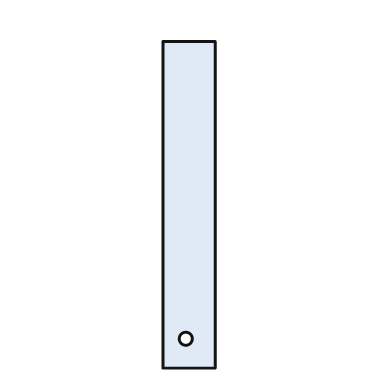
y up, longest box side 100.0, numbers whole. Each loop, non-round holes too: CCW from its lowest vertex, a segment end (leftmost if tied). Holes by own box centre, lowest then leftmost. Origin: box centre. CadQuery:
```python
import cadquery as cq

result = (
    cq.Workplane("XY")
    .moveTo(-8.0, -50.0)
    .lineTo(8.0, -50.0)
    .lineTo(8.0, 50.0)
    .lineTo(-8.0, 50.0)
    .close()
    .moveTo(-1.0, -41.0)
    .circle(2.0)
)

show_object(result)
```